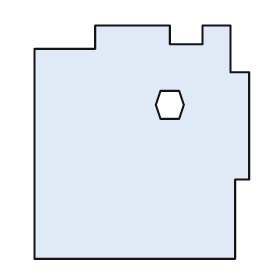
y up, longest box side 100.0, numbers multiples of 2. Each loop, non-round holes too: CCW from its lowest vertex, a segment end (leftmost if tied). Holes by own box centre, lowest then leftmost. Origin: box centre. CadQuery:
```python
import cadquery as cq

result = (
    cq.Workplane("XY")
    .moveTo(-46.0, -50.0)
    .lineTo(40.0, -50.0)
    .lineTo(40.0, -16.0)
    .lineTo(46.0, -16.0)
    .lineTo(46.0, 30.0)
    .lineTo(38.0, 30.0)
    .lineTo(38.0, 50.0)
    .lineTo(26.0, 50.0)
    .lineTo(26.0, 42.0)
    .lineTo(12.0, 42.0)
    .lineTo(12.0, 50.0)
    .lineTo(-20.0, 50.0)
    .lineTo(-20.0, 40.0)
    .lineTo(-46.0, 40.0)
    .close()
    .moveTo(8.0, 10.0)
    .lineTo(16.0, 10.0)
    .lineTo(18.0, 16.0)
    .lineTo(16.0, 22.0)
    .lineTo(8.0, 22.0)
    .lineTo(6.0, 16.0)
    .close()
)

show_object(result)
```